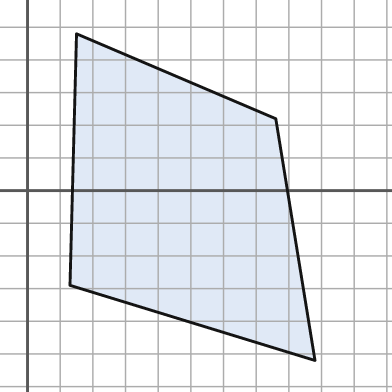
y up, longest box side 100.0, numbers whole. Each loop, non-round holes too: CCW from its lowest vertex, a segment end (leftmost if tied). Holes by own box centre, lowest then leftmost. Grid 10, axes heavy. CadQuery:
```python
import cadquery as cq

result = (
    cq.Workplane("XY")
    .moveTo(88.0, -52.0)
    .lineTo(76.0, 22.0)
    .lineTo(15.0, 48.0)
    .lineTo(13.0, -29.0)
    .close()
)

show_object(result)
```